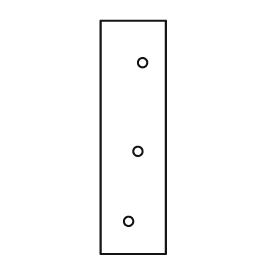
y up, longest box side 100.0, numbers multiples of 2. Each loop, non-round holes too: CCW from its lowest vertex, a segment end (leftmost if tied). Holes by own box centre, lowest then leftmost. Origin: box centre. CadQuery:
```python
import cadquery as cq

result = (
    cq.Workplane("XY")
    .moveTo(-14.0, -50.0)
    .lineTo(14.0, -50.0)
    .lineTo(14.0, 50.0)
    .lineTo(-14.0, 50.0)
    .close()
    .moveTo(-2.0, -36.0)
    .circle(2.0)
    .moveTo(2.0, -6.0)
    .circle(2.0)
    .moveTo(4.0, 32.0)
    .circle(2.0)
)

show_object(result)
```